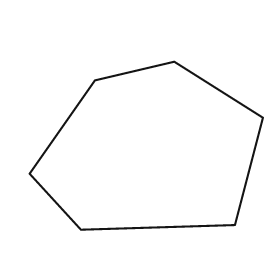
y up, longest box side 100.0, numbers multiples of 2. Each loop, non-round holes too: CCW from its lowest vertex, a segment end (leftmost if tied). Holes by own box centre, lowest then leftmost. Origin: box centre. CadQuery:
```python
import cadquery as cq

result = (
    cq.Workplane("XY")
    .moveTo(-28.0, -36.0)
    .lineTo(38.0, -34.0)
    .lineTo(50.0, 12.0)
    .lineTo(12.0, 36.0)
    .lineTo(-22.0, 28.0)
    .lineTo(-50.0, -12.0)
    .close()
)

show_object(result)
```